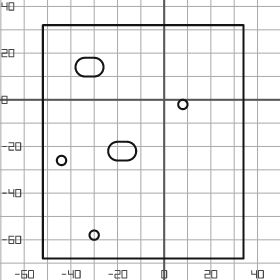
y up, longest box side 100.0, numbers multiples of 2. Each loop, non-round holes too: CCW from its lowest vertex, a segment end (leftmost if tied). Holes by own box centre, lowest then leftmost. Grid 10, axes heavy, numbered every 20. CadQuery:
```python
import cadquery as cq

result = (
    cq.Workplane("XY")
    .moveTo(-52.0, -68.0)
    .lineTo(34.0, -68.0)
    .lineTo(34.0, 32.0)
    .lineTo(-52.0, 32.0)
    .close()
    .moveTo(-30.0, -58.0)
    .circle(2.0)
    .moveTo(-44.0, -26.0)
    .circle(2.0)
    .moveTo(-20.0, -26.0)
    .lineTo(-16.0, -26.0)
    .threePointArc((-12.0, -22.0), (-16.0, -18.0))
    .lineTo(-20.0, -18.0)
    .threePointArc((-24.0, -22.0), (-20.0, -26.0))
    .close()
    .moveTo(8.0, -2.0)
    .circle(2.0)
    .moveTo(-34.0, 10.0)
    .lineTo(-30.0, 10.0)
    .threePointArc((-26.0, 14.0), (-30.0, 18.0))
    .lineTo(-34.0, 18.0)
    .threePointArc((-38.0, 14.0), (-34.0, 10.0))
    .close()
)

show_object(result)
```